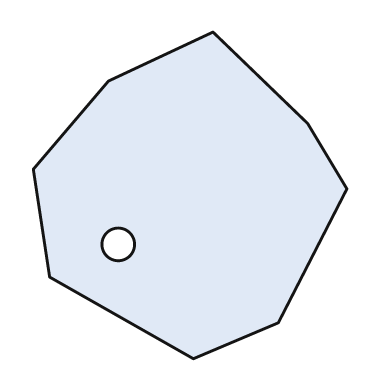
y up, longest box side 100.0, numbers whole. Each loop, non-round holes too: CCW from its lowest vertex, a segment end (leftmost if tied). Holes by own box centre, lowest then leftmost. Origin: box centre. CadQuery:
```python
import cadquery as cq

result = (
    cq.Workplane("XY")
    .moveTo(1.0, -50.0)
    .lineTo(27.0, -39.0)
    .lineTo(48.0, 2.0)
    .lineTo(36.0, 22.0)
    .lineTo(7.0, 50.0)
    .lineTo(-25.0, 35.0)
    .lineTo(-48.0, 8.0)
    .lineTo(-43.0, -25.0)
    .close()
    .moveTo(-22.0, -15.0)
    .circle(5.0)
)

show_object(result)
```